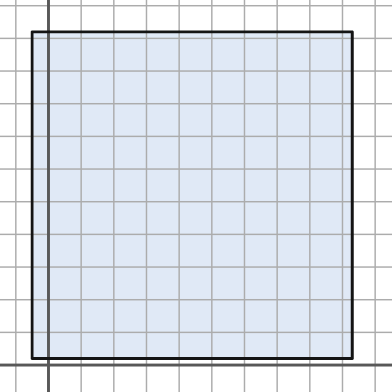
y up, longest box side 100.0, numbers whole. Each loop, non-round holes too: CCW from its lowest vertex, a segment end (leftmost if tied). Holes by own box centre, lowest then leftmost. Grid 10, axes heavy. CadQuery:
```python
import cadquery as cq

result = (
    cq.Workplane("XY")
    .moveTo(-5.0, 2.0)
    .lineTo(93.0, 2.0)
    .lineTo(93.0, 102.0)
    .lineTo(-5.0, 102.0)
    .close()
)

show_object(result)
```